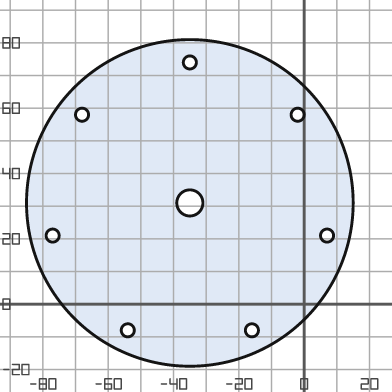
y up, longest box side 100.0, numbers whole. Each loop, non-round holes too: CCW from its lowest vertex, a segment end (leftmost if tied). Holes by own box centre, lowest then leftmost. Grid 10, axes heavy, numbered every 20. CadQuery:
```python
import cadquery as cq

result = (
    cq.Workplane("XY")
    .moveTo(-35.0, 31.0)
    .circle(50.0)
    .moveTo(-54.0, -8.0)
    .circle(2.0)
    .moveTo(-16.0, -8.0)
    .circle(2.0)
    .moveTo(-77.0, 21.0)
    .circle(2.0)
    .moveTo(7.0, 21.0)
    .circle(2.0)
    .moveTo(-35.0, 31.0)
    .circle(4.0)
    .moveTo(-68.0, 58.0)
    .circle(2.0)
    .moveTo(-2.0, 58.0)
    .circle(2.0)
    .moveTo(-35.0, 74.0)
    .circle(2.0)
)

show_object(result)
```